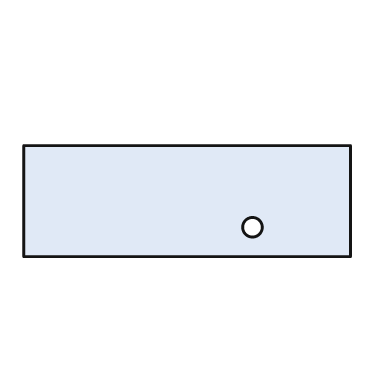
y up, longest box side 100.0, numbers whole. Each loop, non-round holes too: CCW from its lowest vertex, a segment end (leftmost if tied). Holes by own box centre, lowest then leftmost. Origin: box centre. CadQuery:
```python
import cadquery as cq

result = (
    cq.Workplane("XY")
    .moveTo(-50.0, -17.0)
    .lineTo(50.0, -17.0)
    .lineTo(50.0, 17.0)
    .lineTo(-50.0, 17.0)
    .close()
    .moveTo(20.0, -8.0)
    .circle(3.0)
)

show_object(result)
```